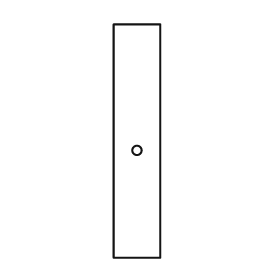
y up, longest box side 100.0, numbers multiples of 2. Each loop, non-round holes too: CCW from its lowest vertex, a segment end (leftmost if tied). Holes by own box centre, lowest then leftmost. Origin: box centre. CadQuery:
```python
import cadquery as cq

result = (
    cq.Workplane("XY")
    .moveTo(-10.0, -50.0)
    .lineTo(10.0, -50.0)
    .lineTo(10.0, 50.0)
    .lineTo(-10.0, 50.0)
    .close()
    .moveTo(0.0, -4.0)
    .circle(2.0)
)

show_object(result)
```